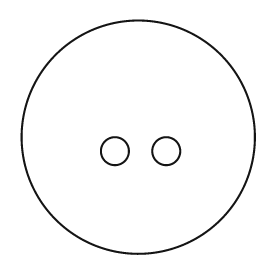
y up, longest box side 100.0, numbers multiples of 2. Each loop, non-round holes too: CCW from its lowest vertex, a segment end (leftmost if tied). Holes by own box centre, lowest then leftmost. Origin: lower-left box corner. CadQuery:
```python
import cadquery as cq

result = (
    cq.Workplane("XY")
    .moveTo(50.0, 50.0)
    .circle(50.0)
    .moveTo(40.0, 44.0)
    .circle(6.0)
    .moveTo(62.0, 44.0)
    .circle(6.0)
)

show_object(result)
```